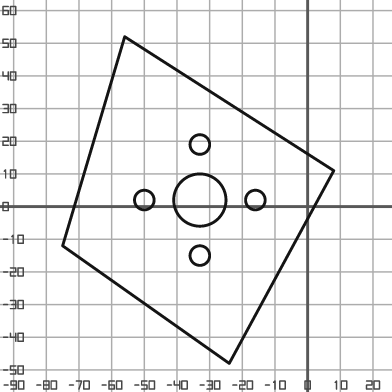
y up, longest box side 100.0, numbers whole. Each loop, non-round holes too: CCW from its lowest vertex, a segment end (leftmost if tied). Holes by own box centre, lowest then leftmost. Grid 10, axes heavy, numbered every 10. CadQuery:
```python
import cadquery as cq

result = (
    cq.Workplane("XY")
    .moveTo(-24.0, -48.0)
    .lineTo(8.0, 11.0)
    .lineTo(-56.0, 52.0)
    .lineTo(-75.0, -12.0)
    .close()
    .moveTo(-33.0, -15.0)
    .circle(3.0)
    .moveTo(-50.0, 2.0)
    .circle(3.0)
    .moveTo(-33.0, 2.0)
    .circle(8.0)
    .moveTo(-16.0, 2.0)
    .circle(3.0)
    .moveTo(-33.0, 19.0)
    .circle(3.0)
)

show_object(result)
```